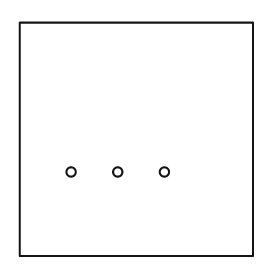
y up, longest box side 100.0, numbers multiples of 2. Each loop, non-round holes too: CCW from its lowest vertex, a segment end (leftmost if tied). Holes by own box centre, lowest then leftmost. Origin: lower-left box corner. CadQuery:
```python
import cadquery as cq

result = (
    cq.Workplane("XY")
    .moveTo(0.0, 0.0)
    .lineTo(100.0, 0.0)
    .lineTo(100.0, 100.0)
    .lineTo(0.0, 100.0)
    .close()
    .moveTo(22.0, 36.0)
    .circle(2.0)
    .moveTo(42.0, 36.0)
    .circle(2.0)
    .moveTo(62.0, 36.0)
    .circle(2.0)
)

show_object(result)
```